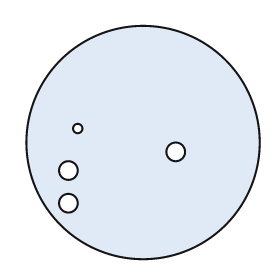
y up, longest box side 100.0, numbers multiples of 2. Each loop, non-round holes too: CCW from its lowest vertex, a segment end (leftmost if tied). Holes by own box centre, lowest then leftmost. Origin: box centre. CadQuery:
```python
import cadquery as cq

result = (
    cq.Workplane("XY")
    .moveTo(0.0, 0.0)
    .circle(50.0)
    .moveTo(-32.0, -26.0)
    .circle(4.0)
    .moveTo(-32.0, -12.0)
    .circle(4.0)
    .moveTo(14.0, -4.0)
    .circle(4.0)
    .moveTo(-28.0, 6.0)
    .circle(2.0)
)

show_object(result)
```